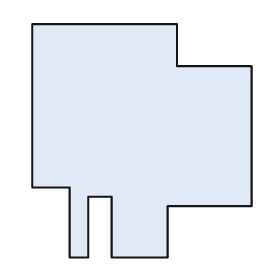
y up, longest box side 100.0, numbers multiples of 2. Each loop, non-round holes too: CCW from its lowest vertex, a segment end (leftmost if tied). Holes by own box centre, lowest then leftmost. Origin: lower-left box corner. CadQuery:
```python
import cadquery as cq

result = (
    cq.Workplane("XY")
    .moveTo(16.0, 0.0)
    .lineTo(24.0, 0.0)
    .lineTo(24.0, 26.0)
    .lineTo(34.0, 26.0)
    .lineTo(34.0, 0.0)
    .lineTo(58.0, 0.0)
    .lineTo(58.0, 22.0)
    .lineTo(94.0, 22.0)
    .lineTo(94.0, 82.0)
    .lineTo(62.0, 82.0)
    .lineTo(62.0, 100.0)
    .lineTo(0.0, 100.0)
    .lineTo(0.0, 30.0)
    .lineTo(16.0, 30.0)
    .close()
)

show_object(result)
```